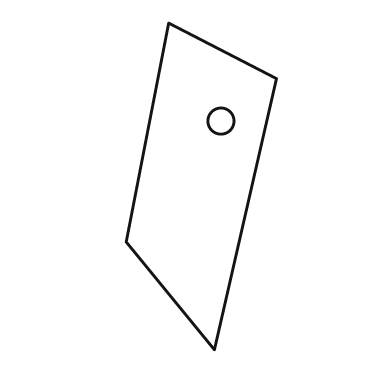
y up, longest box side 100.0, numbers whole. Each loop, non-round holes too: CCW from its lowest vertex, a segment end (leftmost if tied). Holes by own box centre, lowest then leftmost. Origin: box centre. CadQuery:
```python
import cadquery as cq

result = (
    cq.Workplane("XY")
    .moveTo(4.0, -50.0)
    .lineTo(23.0, 33.0)
    .lineTo(-10.0, 50.0)
    .lineTo(-23.0, -17.0)
    .close()
    .moveTo(6.0, 20.0)
    .circle(4.0)
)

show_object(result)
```